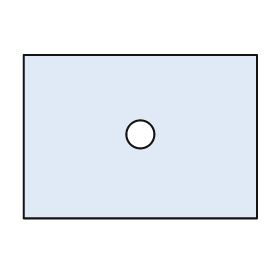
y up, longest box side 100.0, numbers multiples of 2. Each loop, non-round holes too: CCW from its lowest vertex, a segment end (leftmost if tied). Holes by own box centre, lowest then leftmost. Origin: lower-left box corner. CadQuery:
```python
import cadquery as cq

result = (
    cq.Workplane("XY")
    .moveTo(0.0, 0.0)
    .lineTo(100.0, 0.0)
    .lineTo(100.0, 70.0)
    .lineTo(0.0, 70.0)
    .close()
    .moveTo(50.0, 36.0)
    .circle(6.0)
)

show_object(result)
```